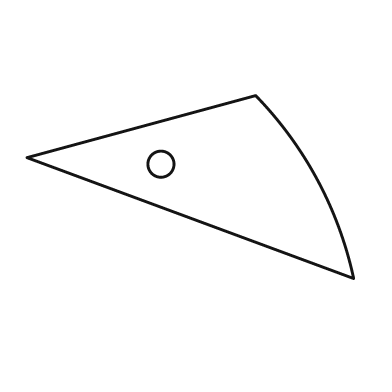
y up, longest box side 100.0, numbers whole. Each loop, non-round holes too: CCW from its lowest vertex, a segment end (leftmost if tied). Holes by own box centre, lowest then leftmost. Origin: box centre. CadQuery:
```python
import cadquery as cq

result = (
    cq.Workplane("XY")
    .moveTo(50.0, -28.0)
    .threePointArc((39.0, 2.0), (20.0, 28.0))
    .lineTo(-50.0, 9.0)
    .close()
    .moveTo(-9.0, 7.0)
    .circle(4.0)
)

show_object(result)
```